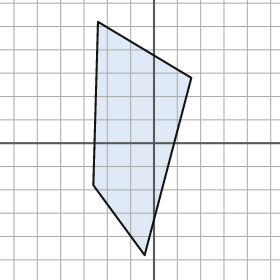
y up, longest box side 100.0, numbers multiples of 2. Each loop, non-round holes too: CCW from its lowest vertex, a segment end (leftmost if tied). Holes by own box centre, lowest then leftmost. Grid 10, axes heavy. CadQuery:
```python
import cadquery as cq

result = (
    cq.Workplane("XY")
    .moveTo(-4.0, -48.0)
    .lineTo(16.0, 28.0)
    .lineTo(-24.0, 52.0)
    .lineTo(-26.0, -18.0)
    .close()
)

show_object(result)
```